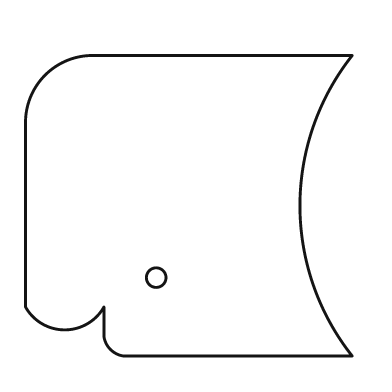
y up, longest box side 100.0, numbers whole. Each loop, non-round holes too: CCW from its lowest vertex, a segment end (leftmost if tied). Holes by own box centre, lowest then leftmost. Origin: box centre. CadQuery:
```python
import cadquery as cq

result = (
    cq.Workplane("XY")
    .moveTo(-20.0, -46.0)
    .lineTo(50.0, -46.0)
    .threePointArc((34.0, 0.0), (50.0, 46.0))
    .lineTo(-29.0, 46.0)
    .threePointArc((-44.0, 40.0), (-50.0, 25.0))
    .lineTo(-50.0, -31.0)
    .threePointArc((-38.0, -38.0), (-26.0, -31.0))
    .lineTo(-26.0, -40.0)
    .threePointArc((-24.0, -44.0), (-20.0, -46.0))
    .close()
    .moveTo(-10.0, -22.0)
    .circle(3.0)
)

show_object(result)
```